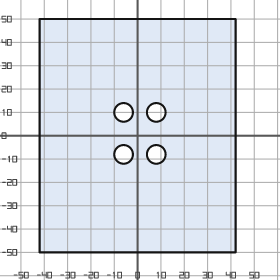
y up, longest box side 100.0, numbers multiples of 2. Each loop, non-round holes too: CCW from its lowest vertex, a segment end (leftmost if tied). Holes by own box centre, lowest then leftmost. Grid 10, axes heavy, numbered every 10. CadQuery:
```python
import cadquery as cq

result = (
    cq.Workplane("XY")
    .moveTo(-42.0, -50.0)
    .lineTo(42.0, -50.0)
    .lineTo(42.0, 50.0)
    .lineTo(-42.0, 50.0)
    .close()
    .moveTo(-6.0, -8.0)
    .circle(4.0)
    .moveTo(8.0, -8.0)
    .circle(4.0)
    .moveTo(-6.0, 10.0)
    .circle(4.0)
    .moveTo(8.0, 10.0)
    .circle(4.0)
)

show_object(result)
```